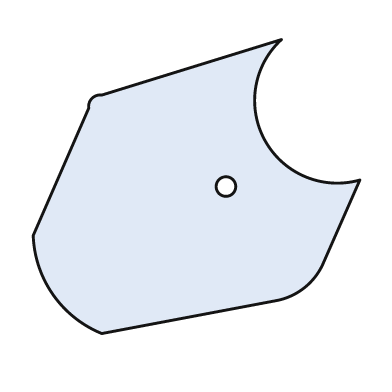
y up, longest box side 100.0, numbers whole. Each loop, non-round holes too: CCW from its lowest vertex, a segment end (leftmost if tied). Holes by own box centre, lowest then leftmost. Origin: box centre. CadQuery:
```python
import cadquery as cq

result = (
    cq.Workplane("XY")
    .moveTo(-29.0, -45.0)
    .lineTo(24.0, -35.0)
    .threePointArc((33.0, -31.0), (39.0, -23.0))
    .lineTo(50.0, 2.0)
    .threePointArc((21.0, 14.0), (26.0, 45.0))
    .lineTo(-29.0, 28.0)
    .threePointArc((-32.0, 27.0), (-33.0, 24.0))
    .lineTo(-50.0, -15.0)
    .threePointArc((-44.0, -33.0), (-29.0, -45.0))
    .close()
    .moveTo(9.0, 0.0)
    .circle(3.0)
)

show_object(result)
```